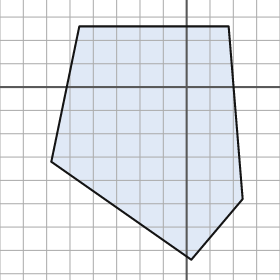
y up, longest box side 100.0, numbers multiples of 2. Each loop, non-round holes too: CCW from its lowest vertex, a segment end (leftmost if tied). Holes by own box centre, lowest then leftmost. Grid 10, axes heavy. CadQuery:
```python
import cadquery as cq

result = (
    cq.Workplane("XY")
    .moveTo(2.0, -74.0)
    .lineTo(24.0, -48.0)
    .lineTo(18.0, 26.0)
    .lineTo(-46.0, 26.0)
    .lineTo(-58.0, -32.0)
    .close()
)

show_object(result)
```